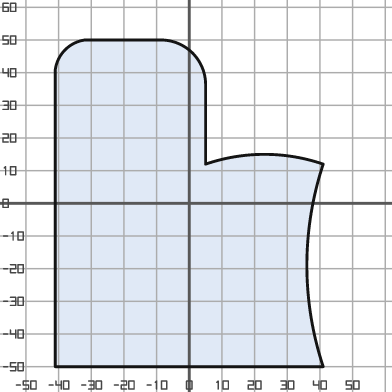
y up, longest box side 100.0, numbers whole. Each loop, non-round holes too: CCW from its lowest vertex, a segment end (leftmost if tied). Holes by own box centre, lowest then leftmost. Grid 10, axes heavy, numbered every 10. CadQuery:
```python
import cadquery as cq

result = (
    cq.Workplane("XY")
    .moveTo(-41.0, -50.0)
    .lineTo(41.0, -50.0)
    .threePointArc((36.0, -19.0), (41.0, 12.0))
    .threePointArc((23.0, 15.0), (5.0, 12.0))
    .lineTo(5.0, 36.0)
    .threePointArc((1.0, 46.0), (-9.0, 50.0))
    .lineTo(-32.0, 50.0)
    .threePointArc((-38.0, 47.0), (-41.0, 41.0))
    .close()
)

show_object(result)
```